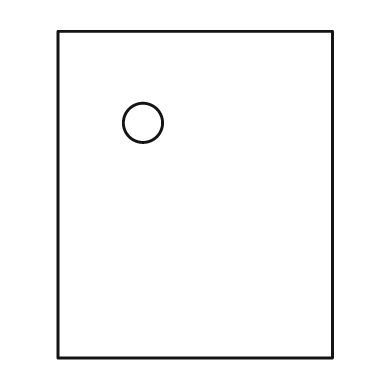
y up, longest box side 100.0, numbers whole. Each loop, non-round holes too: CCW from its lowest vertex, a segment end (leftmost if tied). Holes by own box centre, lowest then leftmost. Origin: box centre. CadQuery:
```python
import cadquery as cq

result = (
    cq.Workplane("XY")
    .moveTo(-42.0, -50.0)
    .lineTo(42.0, -50.0)
    .lineTo(42.0, 50.0)
    .lineTo(-42.0, 50.0)
    .close()
    .moveTo(-16.0, 22.0)
    .circle(6.0)
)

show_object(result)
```